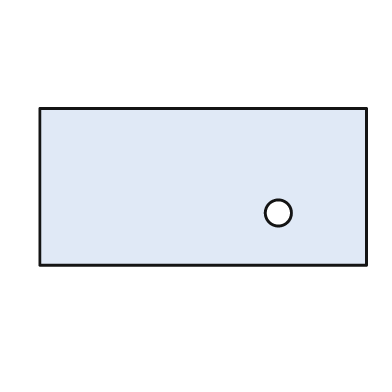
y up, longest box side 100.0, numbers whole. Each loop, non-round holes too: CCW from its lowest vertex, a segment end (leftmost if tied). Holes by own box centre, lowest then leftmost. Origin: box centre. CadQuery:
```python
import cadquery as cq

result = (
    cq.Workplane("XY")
    .moveTo(-50.0, -24.0)
    .lineTo(50.0, -24.0)
    .lineTo(50.0, 24.0)
    .lineTo(-50.0, 24.0)
    .close()
    .moveTo(23.0, -8.0)
    .circle(4.0)
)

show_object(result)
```